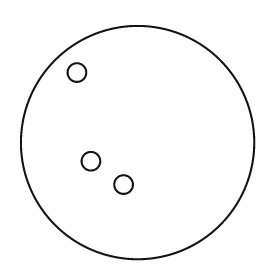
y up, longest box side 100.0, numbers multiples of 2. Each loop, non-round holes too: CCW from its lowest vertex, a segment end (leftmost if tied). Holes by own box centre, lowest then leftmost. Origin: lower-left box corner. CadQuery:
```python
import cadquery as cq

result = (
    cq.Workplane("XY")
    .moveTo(50.0, 50.0)
    .circle(50.0)
    .moveTo(44.0, 32.0)
    .circle(4.0)
    .moveTo(30.0, 42.0)
    .circle(4.0)
    .moveTo(24.0, 80.0)
    .circle(4.0)
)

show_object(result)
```